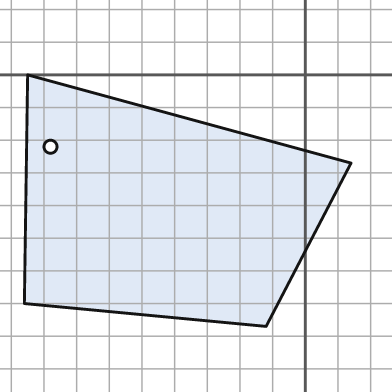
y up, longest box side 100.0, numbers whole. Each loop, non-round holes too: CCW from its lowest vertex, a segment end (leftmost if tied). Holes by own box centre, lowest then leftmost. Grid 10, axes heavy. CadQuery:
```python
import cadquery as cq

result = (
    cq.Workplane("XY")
    .moveTo(-12.0, -77.0)
    .lineTo(14.0, -27.0)
    .lineTo(-85.0, 0.0)
    .lineTo(-86.0, -70.0)
    .close()
    .moveTo(-78.0, -22.0)
    .circle(2.0)
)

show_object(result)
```